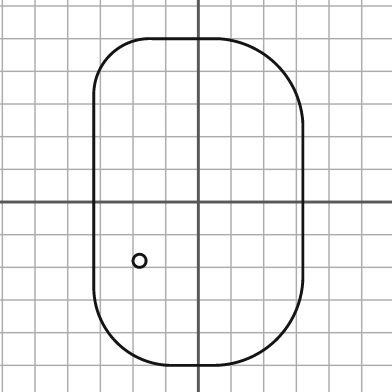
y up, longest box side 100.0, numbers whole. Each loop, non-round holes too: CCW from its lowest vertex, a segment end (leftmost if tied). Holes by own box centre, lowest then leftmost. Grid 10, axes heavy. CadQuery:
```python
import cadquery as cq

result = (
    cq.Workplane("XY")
    .moveTo(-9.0, -50.0)
    .lineTo(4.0, -50.0)
    .threePointArc((24.0, -42.0), (32.0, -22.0))
    .lineTo(32.0, 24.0)
    .threePointArc((24.0, 42.0), (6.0, 50.0))
    .lineTo(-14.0, 50.0)
    .threePointArc((-27.0, 45.0), (-32.0, 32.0))
    .lineTo(-32.0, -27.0)
    .threePointArc((-25.0, -43.0), (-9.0, -50.0))
    .close()
    .moveTo(-18.0, -18.0)
    .circle(2.0)
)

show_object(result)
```